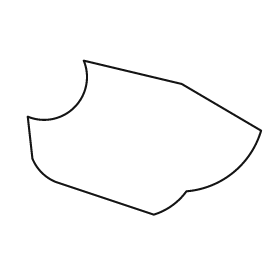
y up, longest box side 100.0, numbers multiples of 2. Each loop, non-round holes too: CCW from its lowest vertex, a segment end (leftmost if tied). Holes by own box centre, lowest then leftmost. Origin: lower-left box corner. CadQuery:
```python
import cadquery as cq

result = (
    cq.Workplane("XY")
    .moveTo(54.0, 0.0)
    .threePointArc((62.0, 4.0), (68.0, 10.0))
    .threePointArc((88.0, 18.0), (100.0, 36.0))
    .lineTo(66.0, 56.0)
    .lineTo(24.0, 66.0)
    .threePointArc((20.0, 46.0), (0.0, 42.0))
    .lineTo(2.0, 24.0)
    .threePointArc((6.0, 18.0), (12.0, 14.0))
    .close()
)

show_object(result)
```